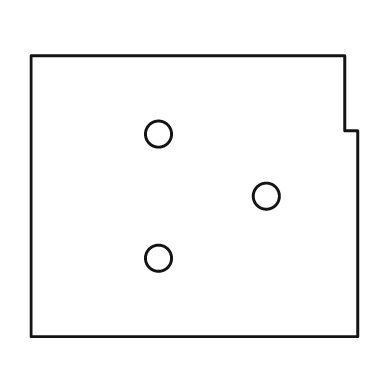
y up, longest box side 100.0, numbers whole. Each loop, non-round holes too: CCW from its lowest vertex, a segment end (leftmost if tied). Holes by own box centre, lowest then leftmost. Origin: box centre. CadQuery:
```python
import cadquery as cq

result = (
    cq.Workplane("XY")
    .moveTo(-50.0, -43.0)
    .lineTo(50.0, -43.0)
    .lineTo(50.0, 20.0)
    .lineTo(46.0, 20.0)
    .lineTo(46.0, 43.0)
    .lineTo(-50.0, 43.0)
    .close()
    .moveTo(-11.0, -19.0)
    .circle(4.0)
    .moveTo(22.0, 0.0)
    .circle(4.0)
    .moveTo(-11.0, 19.0)
    .circle(4.0)
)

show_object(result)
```